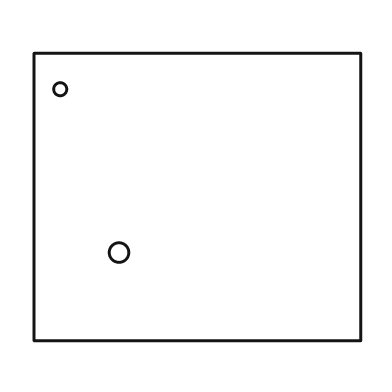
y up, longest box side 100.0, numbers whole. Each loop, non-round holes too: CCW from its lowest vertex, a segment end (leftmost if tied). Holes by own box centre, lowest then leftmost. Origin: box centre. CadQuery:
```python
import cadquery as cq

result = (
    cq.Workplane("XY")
    .moveTo(-50.0, -44.0)
    .lineTo(50.0, -44.0)
    .lineTo(50.0, 44.0)
    .lineTo(-50.0, 44.0)
    .close()
    .moveTo(-24.0, -17.0)
    .circle(3.0)
    .moveTo(-42.0, 33.0)
    .circle(2.0)
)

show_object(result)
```